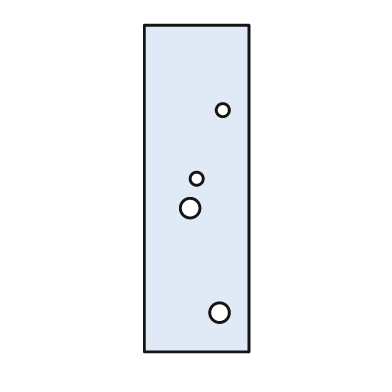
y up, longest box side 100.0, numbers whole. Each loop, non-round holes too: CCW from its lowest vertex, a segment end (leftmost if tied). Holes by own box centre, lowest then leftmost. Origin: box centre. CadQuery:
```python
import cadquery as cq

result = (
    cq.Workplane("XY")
    .moveTo(-16.0, -50.0)
    .lineTo(16.0, -50.0)
    .lineTo(16.0, 50.0)
    .lineTo(-16.0, 50.0)
    .close()
    .moveTo(7.0, -38.0)
    .circle(3.0)
    .moveTo(-2.0, -6.0)
    .circle(3.0)
    .moveTo(0.0, 3.0)
    .circle(2.0)
    .moveTo(8.0, 24.0)
    .circle(2.0)
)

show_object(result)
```